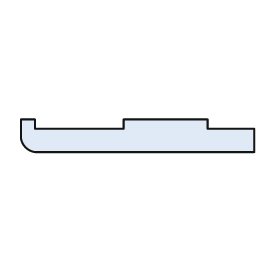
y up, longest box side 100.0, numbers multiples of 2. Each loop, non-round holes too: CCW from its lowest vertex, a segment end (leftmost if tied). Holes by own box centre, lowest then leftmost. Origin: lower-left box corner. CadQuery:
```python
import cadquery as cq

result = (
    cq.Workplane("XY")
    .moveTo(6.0, 0.0)
    .lineTo(100.0, 0.0)
    .lineTo(100.0, 10.0)
    .lineTo(80.0, 10.0)
    .lineTo(80.0, 14.0)
    .lineTo(44.0, 14.0)
    .lineTo(44.0, 10.0)
    .lineTo(6.0, 10.0)
    .lineTo(6.0, 14.0)
    .lineTo(0.0, 14.0)
    .lineTo(0.0, 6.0)
    .threePointArc((2.0, 2.0), (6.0, 0.0))
    .close()
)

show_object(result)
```